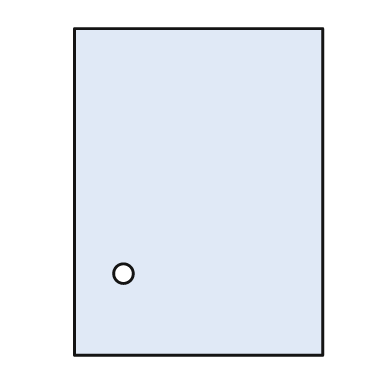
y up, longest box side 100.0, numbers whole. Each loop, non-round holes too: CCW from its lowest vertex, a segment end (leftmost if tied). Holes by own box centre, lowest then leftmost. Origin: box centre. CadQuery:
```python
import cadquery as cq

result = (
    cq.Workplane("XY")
    .moveTo(-38.0, -50.0)
    .lineTo(38.0, -50.0)
    .lineTo(38.0, 50.0)
    .lineTo(-38.0, 50.0)
    .close()
    .moveTo(-23.0, -25.0)
    .circle(3.0)
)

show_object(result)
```